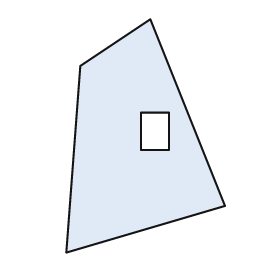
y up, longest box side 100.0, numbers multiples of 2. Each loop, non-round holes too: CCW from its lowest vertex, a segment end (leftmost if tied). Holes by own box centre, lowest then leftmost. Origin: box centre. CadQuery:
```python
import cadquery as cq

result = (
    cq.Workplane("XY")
    .moveTo(-34.0, -50.0)
    .lineTo(34.0, -30.0)
    .lineTo(2.0, 50.0)
    .lineTo(-28.0, 30.0)
    .close()
    .moveTo(-2.0, -6.0)
    .lineTo(10.0, -6.0)
    .lineTo(10.0, 10.0)
    .lineTo(-2.0, 10.0)
    .close()
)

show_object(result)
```